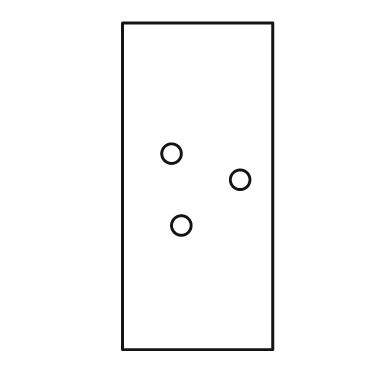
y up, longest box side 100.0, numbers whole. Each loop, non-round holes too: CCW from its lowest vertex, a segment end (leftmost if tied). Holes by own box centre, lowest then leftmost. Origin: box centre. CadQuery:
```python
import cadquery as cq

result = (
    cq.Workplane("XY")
    .moveTo(-23.0, -50.0)
    .lineTo(23.0, -50.0)
    .lineTo(23.0, 50.0)
    .lineTo(-23.0, 50.0)
    .close()
    .moveTo(-5.0, -12.0)
    .circle(3.0)
    .moveTo(13.0, 2.0)
    .circle(3.0)
    .moveTo(-8.0, 10.0)
    .circle(3.0)
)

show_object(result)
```